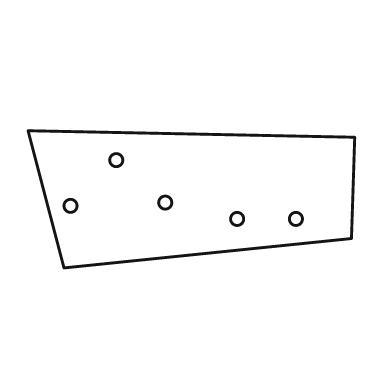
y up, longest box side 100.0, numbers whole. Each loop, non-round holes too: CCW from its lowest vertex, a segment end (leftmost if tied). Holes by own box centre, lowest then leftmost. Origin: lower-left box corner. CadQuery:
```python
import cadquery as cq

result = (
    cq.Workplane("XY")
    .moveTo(11.0, 0.0)
    .lineTo(99.0, 9.0)
    .lineTo(100.0, 40.0)
    .lineTo(0.0, 42.0)
    .close()
    .moveTo(64.0, 15.0)
    .circle(2.0)
    .moveTo(82.0, 15.0)
    .circle(2.0)
    .moveTo(13.0, 19.0)
    .circle(2.0)
    .moveTo(42.0, 20.0)
    .circle(2.0)
    .moveTo(27.0, 33.0)
    .circle(2.0)
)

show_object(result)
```